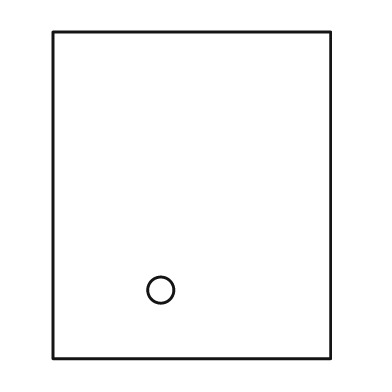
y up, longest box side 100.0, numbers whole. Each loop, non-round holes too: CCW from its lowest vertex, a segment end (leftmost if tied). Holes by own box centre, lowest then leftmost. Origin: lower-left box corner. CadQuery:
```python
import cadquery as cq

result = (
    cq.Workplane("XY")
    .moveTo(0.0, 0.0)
    .lineTo(85.0, 0.0)
    .lineTo(85.0, 100.0)
    .lineTo(0.0, 100.0)
    .close()
    .moveTo(33.0, 21.0)
    .circle(4.0)
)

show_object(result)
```